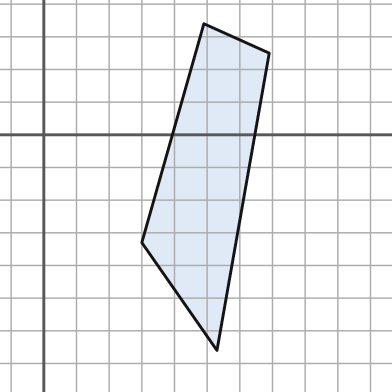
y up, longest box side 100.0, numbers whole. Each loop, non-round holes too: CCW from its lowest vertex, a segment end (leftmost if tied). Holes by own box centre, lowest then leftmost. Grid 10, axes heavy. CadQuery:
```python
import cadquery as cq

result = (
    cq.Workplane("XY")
    .moveTo(53.0, -66.0)
    .lineTo(69.0, 25.0)
    .lineTo(49.0, 34.0)
    .lineTo(30.0, -33.0)
    .close()
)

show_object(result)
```